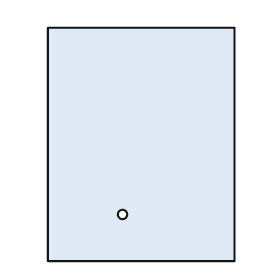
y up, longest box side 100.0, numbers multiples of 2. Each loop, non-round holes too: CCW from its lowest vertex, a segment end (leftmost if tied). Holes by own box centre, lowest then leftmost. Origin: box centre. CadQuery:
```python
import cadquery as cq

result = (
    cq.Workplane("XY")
    .moveTo(-40.0, -50.0)
    .lineTo(40.0, -50.0)
    .lineTo(40.0, 50.0)
    .lineTo(-40.0, 50.0)
    .close()
    .moveTo(-8.0, -30.0)
    .circle(2.0)
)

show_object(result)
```